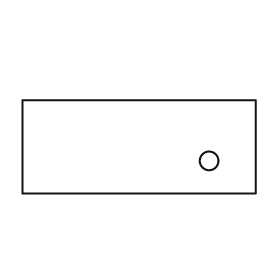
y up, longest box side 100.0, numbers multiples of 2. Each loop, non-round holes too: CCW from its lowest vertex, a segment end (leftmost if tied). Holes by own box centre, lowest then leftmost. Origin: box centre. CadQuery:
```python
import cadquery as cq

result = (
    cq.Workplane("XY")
    .moveTo(-50.0, -20.0)
    .lineTo(50.0, -20.0)
    .lineTo(50.0, 20.0)
    .lineTo(-50.0, 20.0)
    .close()
    .moveTo(30.0, -6.0)
    .circle(4.0)
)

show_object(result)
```